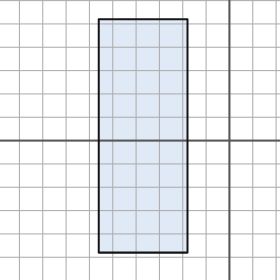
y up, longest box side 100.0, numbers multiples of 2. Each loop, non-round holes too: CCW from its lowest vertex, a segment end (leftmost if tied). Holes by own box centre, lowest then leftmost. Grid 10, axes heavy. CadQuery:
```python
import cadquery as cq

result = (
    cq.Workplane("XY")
    .moveTo(-56.0, -48.0)
    .lineTo(-18.0, -48.0)
    .lineTo(-18.0, 52.0)
    .lineTo(-56.0, 52.0)
    .close()
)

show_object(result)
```